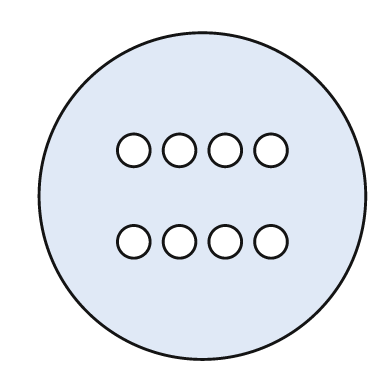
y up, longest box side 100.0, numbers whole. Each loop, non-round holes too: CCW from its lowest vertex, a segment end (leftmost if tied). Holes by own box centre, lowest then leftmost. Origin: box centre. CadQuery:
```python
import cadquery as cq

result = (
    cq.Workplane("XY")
    .moveTo(0.0, 0.0)
    .circle(50.0)
    .moveTo(-21.0, -14.0)
    .circle(5.0)
    .moveTo(-7.0, -14.0)
    .circle(5.0)
    .moveTo(7.0, -14.0)
    .circle(5.0)
    .moveTo(21.0, -14.0)
    .circle(5.0)
    .moveTo(-21.0, 14.0)
    .circle(5.0)
    .moveTo(-7.0, 14.0)
    .circle(5.0)
    .moveTo(7.0, 14.0)
    .circle(5.0)
    .moveTo(21.0, 14.0)
    .circle(5.0)
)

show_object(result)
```